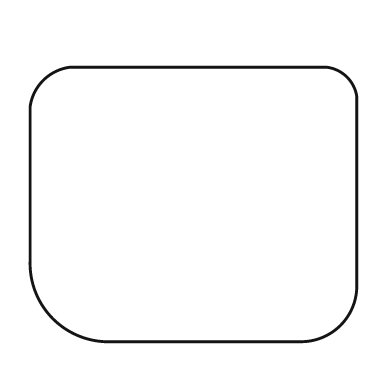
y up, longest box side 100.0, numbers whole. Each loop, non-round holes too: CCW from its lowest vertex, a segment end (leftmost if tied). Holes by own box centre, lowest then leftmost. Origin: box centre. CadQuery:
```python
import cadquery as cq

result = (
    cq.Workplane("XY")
    .moveTo(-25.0, -42.0)
    .lineTo(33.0, -42.0)
    .threePointArc((45.0, -37.0), (50.0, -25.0))
    .lineTo(50.0, 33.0)
    .threePointArc((47.0, 39.0), (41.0, 42.0))
    .lineTo(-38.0, 42.0)
    .threePointArc((-46.0, 38.0), (-50.0, 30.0))
    .lineTo(-50.0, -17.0)
    .threePointArc((-43.0, -35.0), (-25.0, -42.0))
    .close()
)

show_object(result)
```